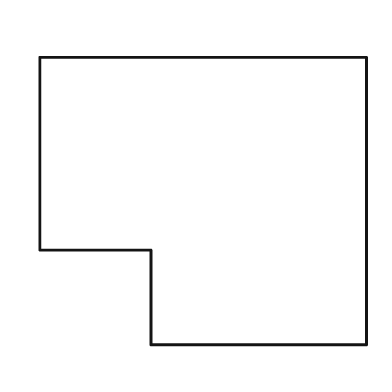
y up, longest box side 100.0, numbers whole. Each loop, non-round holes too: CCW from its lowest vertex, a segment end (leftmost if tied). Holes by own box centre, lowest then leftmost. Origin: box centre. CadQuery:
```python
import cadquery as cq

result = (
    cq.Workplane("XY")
    .moveTo(-16.0, -44.0)
    .lineTo(50.0, -44.0)
    .lineTo(50.0, 44.0)
    .lineTo(-50.0, 44.0)
    .lineTo(-50.0, -15.0)
    .lineTo(-16.0, -15.0)
    .close()
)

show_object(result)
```